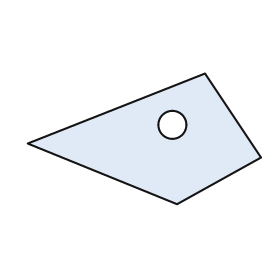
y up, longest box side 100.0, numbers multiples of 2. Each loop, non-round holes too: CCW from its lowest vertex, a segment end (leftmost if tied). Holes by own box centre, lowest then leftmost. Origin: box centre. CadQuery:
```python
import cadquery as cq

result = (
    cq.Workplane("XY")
    .moveTo(14.0, -28.0)
    .lineTo(50.0, -8.0)
    .lineTo(26.0, 28.0)
    .lineTo(-50.0, -2.0)
    .close()
    .moveTo(12.0, 6.0)
    .circle(6.0)
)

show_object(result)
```